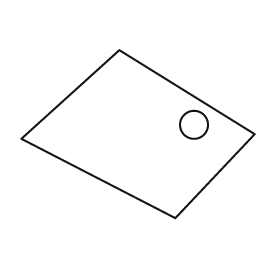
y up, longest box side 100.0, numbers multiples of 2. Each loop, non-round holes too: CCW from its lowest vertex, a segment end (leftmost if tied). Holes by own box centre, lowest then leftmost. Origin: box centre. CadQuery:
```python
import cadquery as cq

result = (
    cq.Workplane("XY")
    .moveTo(16.0, -36.0)
    .lineTo(50.0, 0.0)
    .lineTo(-8.0, 36.0)
    .lineTo(-50.0, -2.0)
    .close()
    .moveTo(24.0, 4.0)
    .circle(6.0)
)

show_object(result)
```